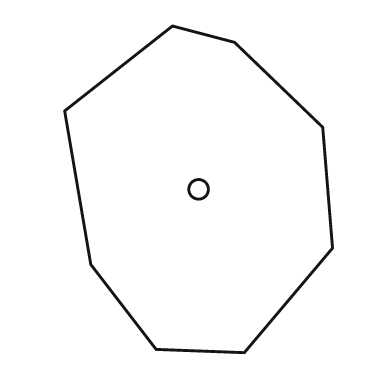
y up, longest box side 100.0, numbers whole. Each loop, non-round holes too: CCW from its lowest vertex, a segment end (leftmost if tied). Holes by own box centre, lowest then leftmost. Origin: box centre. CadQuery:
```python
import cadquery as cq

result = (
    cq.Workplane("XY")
    .moveTo(14.0, -50.0)
    .lineTo(41.0, -18.0)
    .lineTo(38.0, 19.0)
    .lineTo(11.0, 45.0)
    .lineTo(-8.0, 50.0)
    .lineTo(-41.0, 24.0)
    .lineTo(-33.0, -23.0)
    .lineTo(-13.0, -49.0)
    .close()
    .moveTo(0.0, 0.0)
    .circle(3.0)
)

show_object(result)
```